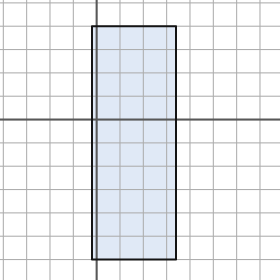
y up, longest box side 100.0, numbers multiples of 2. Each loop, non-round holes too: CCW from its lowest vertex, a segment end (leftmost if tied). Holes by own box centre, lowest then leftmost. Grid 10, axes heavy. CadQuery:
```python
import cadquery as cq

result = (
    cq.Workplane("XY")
    .moveTo(-2.0, -60.0)
    .lineTo(34.0, -60.0)
    .lineTo(34.0, 40.0)
    .lineTo(-2.0, 40.0)
    .close()
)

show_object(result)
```